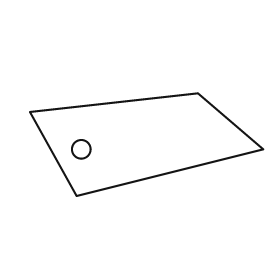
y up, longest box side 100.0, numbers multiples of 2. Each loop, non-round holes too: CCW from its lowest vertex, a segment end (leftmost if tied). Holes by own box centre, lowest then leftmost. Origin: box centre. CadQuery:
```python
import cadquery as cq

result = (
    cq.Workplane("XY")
    .moveTo(-30.0, -22.0)
    .lineTo(50.0, -2.0)
    .lineTo(22.0, 22.0)
    .lineTo(-50.0, 14.0)
    .close()
    .moveTo(-28.0, -2.0)
    .circle(4.0)
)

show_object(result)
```